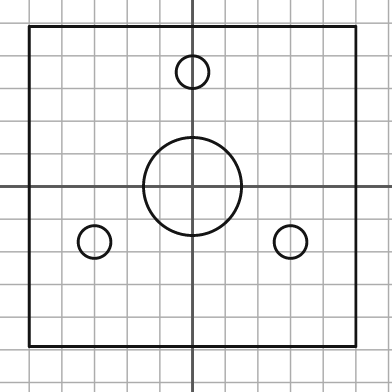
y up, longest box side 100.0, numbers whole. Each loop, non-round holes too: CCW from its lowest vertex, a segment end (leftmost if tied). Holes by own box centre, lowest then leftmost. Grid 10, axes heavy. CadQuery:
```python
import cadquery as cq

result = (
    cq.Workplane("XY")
    .moveTo(-50.0, -49.0)
    .lineTo(50.0, -49.0)
    .lineTo(50.0, 49.0)
    .lineTo(-50.0, 49.0)
    .close()
    .moveTo(-30.0, -17.0)
    .circle(5.0)
    .moveTo(30.0, -17.0)
    .circle(5.0)
    .moveTo(0.0, 0.0)
    .circle(15.0)
    .moveTo(0.0, 35.0)
    .circle(5.0)
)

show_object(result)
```